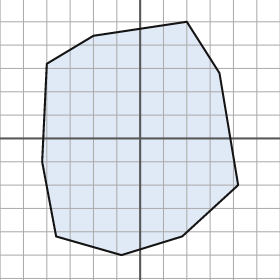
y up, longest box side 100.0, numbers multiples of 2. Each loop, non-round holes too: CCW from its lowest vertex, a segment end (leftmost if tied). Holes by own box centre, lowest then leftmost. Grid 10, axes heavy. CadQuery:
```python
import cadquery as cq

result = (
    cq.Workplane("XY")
    .moveTo(-8.0, -50.0)
    .lineTo(18.0, -42.0)
    .lineTo(42.0, -20.0)
    .lineTo(34.0, 28.0)
    .lineTo(20.0, 50.0)
    .lineTo(-20.0, 44.0)
    .lineTo(-40.0, 32.0)
    .lineTo(-42.0, -10.0)
    .lineTo(-36.0, -42.0)
    .close()
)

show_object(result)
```